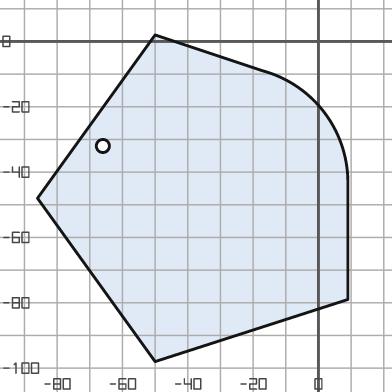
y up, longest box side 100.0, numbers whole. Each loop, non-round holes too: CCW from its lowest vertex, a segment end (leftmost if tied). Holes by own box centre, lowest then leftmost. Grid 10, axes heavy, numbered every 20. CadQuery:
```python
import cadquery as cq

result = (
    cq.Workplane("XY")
    .moveTo(-50.0, -98.0)
    .lineTo(9.0, -79.0)
    .lineTo(9.0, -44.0)
    .threePointArc((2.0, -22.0), (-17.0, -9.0))
    .lineTo(-50.0, 2.0)
    .lineTo(-86.0, -48.0)
    .close()
    .moveTo(-66.0, -32.0)
    .circle(2.0)
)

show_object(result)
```